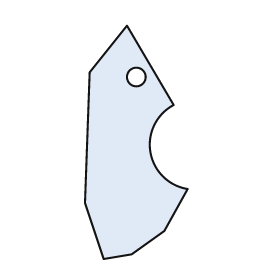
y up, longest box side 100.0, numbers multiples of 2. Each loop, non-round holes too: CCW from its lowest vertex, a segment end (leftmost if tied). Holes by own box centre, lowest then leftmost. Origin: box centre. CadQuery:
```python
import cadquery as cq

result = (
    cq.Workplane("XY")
    .moveTo(-14.0, -50.0)
    .lineTo(-2.0, -48.0)
    .lineTo(12.0, -38.0)
    .lineTo(22.0, -20.0)
    .threePointArc((6.0, -4.0), (16.0, 16.0))
    .lineTo(-4.0, 50.0)
    .lineTo(-20.0, 30.0)
    .lineTo(-22.0, -26.0)
    .close()
    .moveTo(0.0, 28.0)
    .circle(4.0)
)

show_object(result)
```